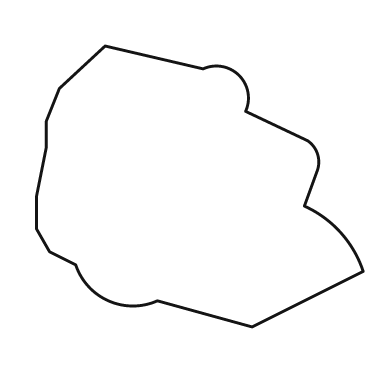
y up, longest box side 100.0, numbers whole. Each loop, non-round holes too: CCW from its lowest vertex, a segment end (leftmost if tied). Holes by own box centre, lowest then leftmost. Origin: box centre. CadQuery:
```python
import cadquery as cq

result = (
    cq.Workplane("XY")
    .moveTo(16.0, -43.0)
    .lineTo(50.0, -26.0)
    .threePointArc((43.0, -14.0), (32.0, -6.0))
    .lineTo(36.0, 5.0)
    .threePointArc((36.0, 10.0), (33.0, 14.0))
    .lineTo(14.0, 23.0)
    .threePointArc((12.0, 34.0), (1.0, 36.0))
    .lineTo(-29.0, 43.0)
    .lineTo(-43.0, 30.0)
    .lineTo(-47.0, 20.0)
    .lineTo(-47.0, 12.0)
    .lineTo(-50.0, -3.0)
    .lineTo(-50.0, -13.0)
    .lineTo(-46.0, -20.0)
    .lineTo(-38.0, -24.0)
    .threePointArc((-28.0, -35.0), (-13.0, -35.0))
    .close()
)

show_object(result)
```